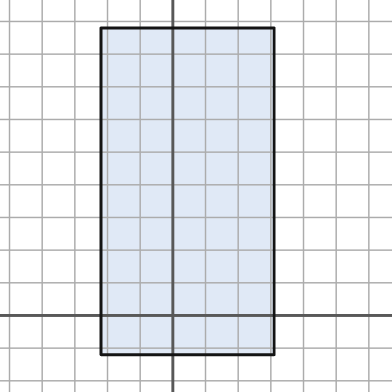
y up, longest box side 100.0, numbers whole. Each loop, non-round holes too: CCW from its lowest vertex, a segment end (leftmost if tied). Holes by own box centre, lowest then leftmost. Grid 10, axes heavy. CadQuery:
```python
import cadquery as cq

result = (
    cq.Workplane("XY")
    .moveTo(-22.0, -12.0)
    .lineTo(31.0, -12.0)
    .lineTo(31.0, 88.0)
    .lineTo(-22.0, 88.0)
    .close()
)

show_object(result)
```